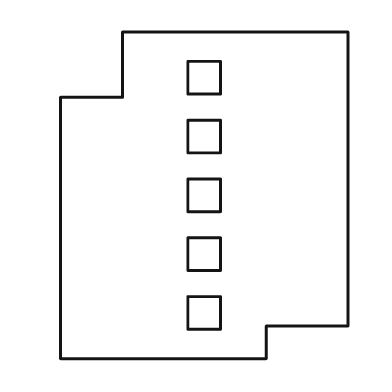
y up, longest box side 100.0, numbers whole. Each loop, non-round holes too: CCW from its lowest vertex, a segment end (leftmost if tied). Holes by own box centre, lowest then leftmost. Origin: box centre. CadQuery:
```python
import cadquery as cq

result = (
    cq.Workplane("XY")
    .moveTo(-44.0, -50.0)
    .lineTo(19.0, -50.0)
    .lineTo(19.0, -40.0)
    .lineTo(44.0, -40.0)
    .lineTo(44.0, 50.0)
    .lineTo(-25.0, 50.0)
    .lineTo(-25.0, 30.0)
    .lineTo(-44.0, 30.0)
    .close()
    .moveTo(-5.0, -41.0)
    .lineTo(5.0, -41.0)
    .lineTo(5.0, -31.0)
    .lineTo(-5.0, -31.0)
    .close()
    .moveTo(-5.0, -23.0)
    .lineTo(5.0, -23.0)
    .lineTo(5.0, -13.0)
    .lineTo(-5.0, -13.0)
    .close()
    .moveTo(-5.0, -5.0)
    .lineTo(5.0, -5.0)
    .lineTo(5.0, 5.0)
    .lineTo(-5.0, 5.0)
    .close()
    .moveTo(-5.0, 13.0)
    .lineTo(5.0, 13.0)
    .lineTo(5.0, 23.0)
    .lineTo(-5.0, 23.0)
    .close()
    .moveTo(-5.0, 31.0)
    .lineTo(5.0, 31.0)
    .lineTo(5.0, 41.0)
    .lineTo(-5.0, 41.0)
    .close()
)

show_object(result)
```